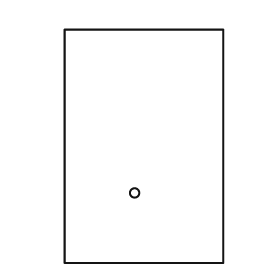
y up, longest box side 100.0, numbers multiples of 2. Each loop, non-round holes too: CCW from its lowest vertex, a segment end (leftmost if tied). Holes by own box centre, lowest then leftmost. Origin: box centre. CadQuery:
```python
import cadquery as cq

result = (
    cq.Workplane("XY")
    .moveTo(-34.0, -50.0)
    .lineTo(34.0, -50.0)
    .lineTo(34.0, 50.0)
    .lineTo(-34.0, 50.0)
    .close()
    .moveTo(-4.0, -20.0)
    .circle(2.0)
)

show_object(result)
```